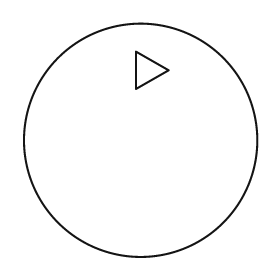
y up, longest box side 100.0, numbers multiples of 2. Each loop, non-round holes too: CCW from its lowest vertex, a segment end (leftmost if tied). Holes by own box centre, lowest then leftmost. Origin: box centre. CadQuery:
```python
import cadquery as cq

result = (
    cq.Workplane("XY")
    .moveTo(0.0, 0.0)
    .circle(50.0)
    .moveTo(-2.0, 22.0)
    .lineTo(12.0, 30.0)
    .lineTo(-2.0, 38.0)
    .close()
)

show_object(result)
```